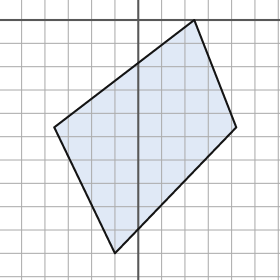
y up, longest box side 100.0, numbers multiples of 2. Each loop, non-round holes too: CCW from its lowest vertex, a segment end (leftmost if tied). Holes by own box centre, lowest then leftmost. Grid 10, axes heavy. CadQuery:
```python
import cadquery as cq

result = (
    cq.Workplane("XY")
    .moveTo(-10.0, -100.0)
    .lineTo(42.0, -46.0)
    .lineTo(24.0, 0.0)
    .lineTo(-36.0, -46.0)
    .close()
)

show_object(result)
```